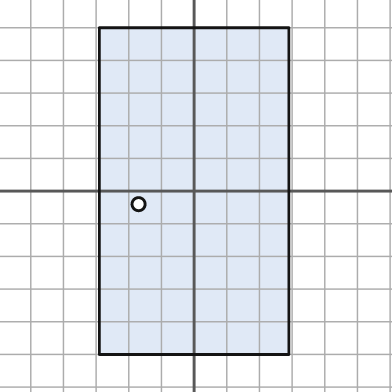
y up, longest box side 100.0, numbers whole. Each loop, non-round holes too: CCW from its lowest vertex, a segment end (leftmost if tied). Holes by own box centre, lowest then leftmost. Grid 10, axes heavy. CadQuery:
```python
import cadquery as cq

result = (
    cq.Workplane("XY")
    .moveTo(-29.0, -50.0)
    .lineTo(29.0, -50.0)
    .lineTo(29.0, 50.0)
    .lineTo(-29.0, 50.0)
    .close()
    .moveTo(-17.0, -4.0)
    .circle(2.0)
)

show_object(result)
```